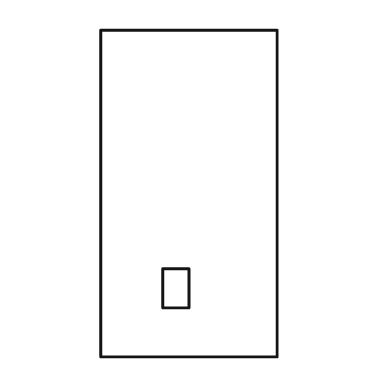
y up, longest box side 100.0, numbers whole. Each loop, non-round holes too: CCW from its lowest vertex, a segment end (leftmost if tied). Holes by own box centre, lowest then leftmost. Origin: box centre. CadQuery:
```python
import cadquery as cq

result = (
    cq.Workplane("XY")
    .moveTo(-27.0, -50.0)
    .lineTo(27.0, -50.0)
    .lineTo(27.0, 50.0)
    .lineTo(-27.0, 50.0)
    .close()
    .moveTo(-8.0, -35.0)
    .lineTo(0.0, -35.0)
    .lineTo(0.0, -23.0)
    .lineTo(-8.0, -23.0)
    .close()
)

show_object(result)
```